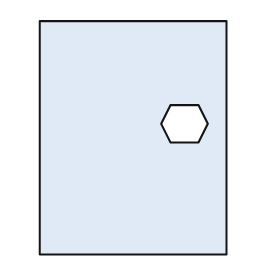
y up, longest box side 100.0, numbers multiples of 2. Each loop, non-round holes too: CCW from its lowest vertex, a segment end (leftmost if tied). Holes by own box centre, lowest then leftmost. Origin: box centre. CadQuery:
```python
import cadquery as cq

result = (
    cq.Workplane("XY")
    .moveTo(-40.0, -50.0)
    .lineTo(40.0, -50.0)
    .lineTo(40.0, 50.0)
    .lineTo(-40.0, 50.0)
    .close()
    .moveTo(16.0, -2.0)
    .lineTo(28.0, -2.0)
    .lineTo(32.0, 6.0)
    .lineTo(28.0, 14.0)
    .lineTo(16.0, 14.0)
    .lineTo(12.0, 6.0)
    .close()
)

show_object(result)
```